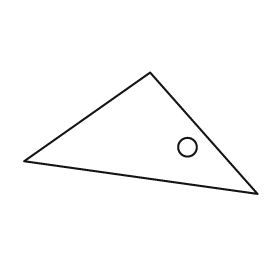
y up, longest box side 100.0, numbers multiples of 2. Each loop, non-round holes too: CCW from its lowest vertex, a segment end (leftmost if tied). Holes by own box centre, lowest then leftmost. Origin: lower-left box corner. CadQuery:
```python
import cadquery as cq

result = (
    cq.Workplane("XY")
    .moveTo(100.0, 0.0)
    .lineTo(54.0, 52.0)
    .lineTo(0.0, 14.0)
    .close()
    .moveTo(70.0, 20.0)
    .circle(4.0)
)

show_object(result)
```